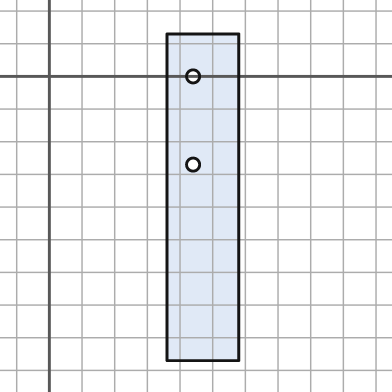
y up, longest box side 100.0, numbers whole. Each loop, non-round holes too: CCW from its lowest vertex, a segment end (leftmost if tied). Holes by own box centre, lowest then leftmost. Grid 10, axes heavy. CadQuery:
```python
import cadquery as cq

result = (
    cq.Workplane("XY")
    .moveTo(36.0, -87.0)
    .lineTo(58.0, -87.0)
    .lineTo(58.0, 13.0)
    .lineTo(36.0, 13.0)
    .close()
    .moveTo(44.0, -27.0)
    .circle(2.0)
    .moveTo(44.0, 0.0)
    .circle(2.0)
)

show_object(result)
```